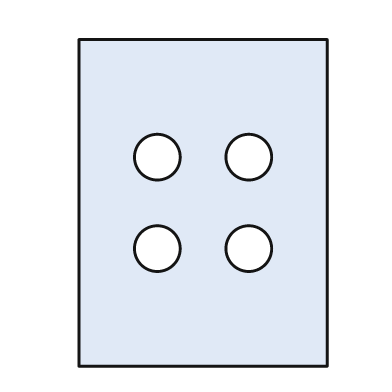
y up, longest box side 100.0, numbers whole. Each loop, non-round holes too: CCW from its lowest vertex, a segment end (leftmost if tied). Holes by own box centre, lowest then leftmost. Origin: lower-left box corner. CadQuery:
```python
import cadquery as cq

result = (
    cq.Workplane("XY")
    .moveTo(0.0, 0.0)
    .lineTo(76.0, 0.0)
    .lineTo(76.0, 100.0)
    .lineTo(0.0, 100.0)
    .close()
    .moveTo(24.0, 36.0)
    .circle(7.0)
    .moveTo(52.0, 36.0)
    .circle(7.0)
    .moveTo(24.0, 64.0)
    .circle(7.0)
    .moveTo(52.0, 64.0)
    .circle(7.0)
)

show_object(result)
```